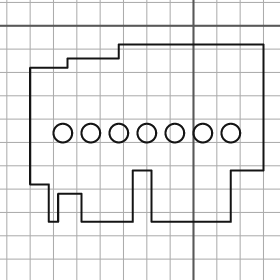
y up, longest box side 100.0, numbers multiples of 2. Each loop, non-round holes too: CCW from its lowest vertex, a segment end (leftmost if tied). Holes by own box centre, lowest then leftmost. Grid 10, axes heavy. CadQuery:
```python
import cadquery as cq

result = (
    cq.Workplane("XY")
    .moveTo(-62.0, -84.0)
    .lineTo(-58.0, -84.0)
    .lineTo(-58.0, -72.0)
    .lineTo(-48.0, -72.0)
    .lineTo(-48.0, -84.0)
    .lineTo(-26.0, -84.0)
    .lineTo(-26.0, -62.0)
    .lineTo(-18.0, -62.0)
    .lineTo(-18.0, -84.0)
    .lineTo(16.0, -84.0)
    .lineTo(16.0, -62.0)
    .lineTo(30.0, -62.0)
    .lineTo(30.0, -8.0)
    .lineTo(-32.0, -8.0)
    .lineTo(-32.0, -14.0)
    .lineTo(-54.0, -14.0)
    .lineTo(-54.0, -18.0)
    .lineTo(-70.0, -18.0)
    .lineTo(-70.0, -68.0)
    .lineTo(-62.0, -68.0)
    .close()
    .moveTo(-56.0, -46.0)
    .circle(4.0)
    .moveTo(-44.0, -46.0)
    .circle(4.0)
    .moveTo(-32.0, -46.0)
    .circle(4.0)
    .moveTo(-20.0, -46.0)
    .circle(4.0)
    .moveTo(-8.0, -46.0)
    .circle(4.0)
    .moveTo(4.0, -46.0)
    .circle(4.0)
    .moveTo(16.0, -46.0)
    .circle(4.0)
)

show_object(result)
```